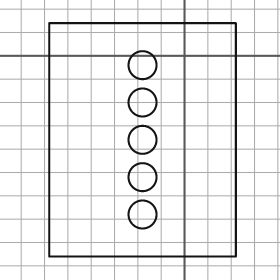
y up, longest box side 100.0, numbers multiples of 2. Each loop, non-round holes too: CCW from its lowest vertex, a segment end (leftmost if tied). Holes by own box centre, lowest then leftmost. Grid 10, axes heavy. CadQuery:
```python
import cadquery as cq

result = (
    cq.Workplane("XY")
    .moveTo(-58.0, -86.0)
    .lineTo(22.0, -86.0)
    .lineTo(22.0, 14.0)
    .lineTo(-58.0, 14.0)
    .close()
    .moveTo(-18.0, -68.0)
    .circle(6.0)
    .moveTo(-18.0, -52.0)
    .circle(6.0)
    .moveTo(-18.0, -36.0)
    .circle(6.0)
    .moveTo(-18.0, -20.0)
    .circle(6.0)
    .moveTo(-18.0, -4.0)
    .circle(6.0)
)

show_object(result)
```